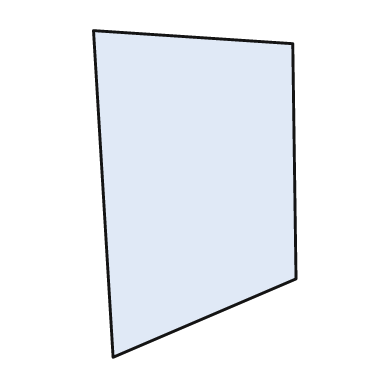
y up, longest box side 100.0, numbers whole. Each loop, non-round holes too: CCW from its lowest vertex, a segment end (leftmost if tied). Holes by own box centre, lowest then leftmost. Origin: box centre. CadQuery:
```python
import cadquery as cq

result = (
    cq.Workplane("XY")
    .moveTo(-25.0, -50.0)
    .lineTo(31.0, -26.0)
    .lineTo(30.0, 46.0)
    .lineTo(-31.0, 50.0)
    .close()
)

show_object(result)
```